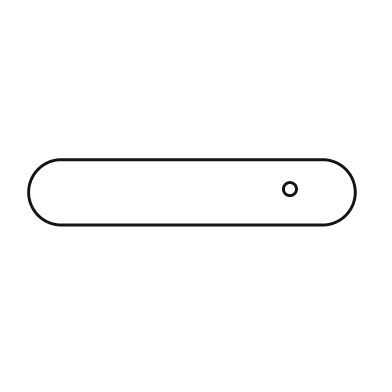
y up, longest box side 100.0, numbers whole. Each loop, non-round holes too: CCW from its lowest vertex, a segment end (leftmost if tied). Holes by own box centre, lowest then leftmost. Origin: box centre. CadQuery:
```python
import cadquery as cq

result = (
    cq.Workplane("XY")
    .moveTo(-40.0, -10.0)
    .lineTo(40.0, -10.0)
    .threePointArc((50.0, 0.0), (40.0, 10.0))
    .lineTo(-40.0, 10.0)
    .threePointArc((-50.0, 0.0), (-40.0, -10.0))
    .close()
    .moveTo(30.0, 1.0)
    .circle(2.0)
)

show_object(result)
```